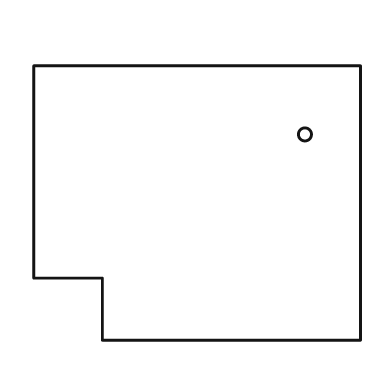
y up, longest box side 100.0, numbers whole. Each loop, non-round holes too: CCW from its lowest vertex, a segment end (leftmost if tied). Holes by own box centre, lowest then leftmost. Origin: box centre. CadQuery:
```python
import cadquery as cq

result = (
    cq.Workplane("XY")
    .moveTo(-29.0, -42.0)
    .lineTo(50.0, -42.0)
    .lineTo(50.0, 42.0)
    .lineTo(-50.0, 42.0)
    .lineTo(-50.0, -23.0)
    .lineTo(-29.0, -23.0)
    .close()
    .moveTo(33.0, 21.0)
    .circle(2.0)
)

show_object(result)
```